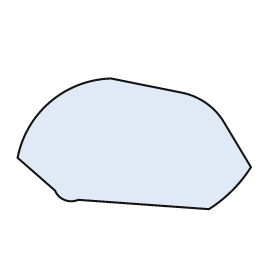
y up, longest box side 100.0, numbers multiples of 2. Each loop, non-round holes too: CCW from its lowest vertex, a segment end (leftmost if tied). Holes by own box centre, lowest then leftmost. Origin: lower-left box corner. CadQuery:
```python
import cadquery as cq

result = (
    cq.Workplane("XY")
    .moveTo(82.0, 0.0)
    .threePointArc((92.0, 8.0), (100.0, 18.0))
    .lineTo(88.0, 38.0)
    .threePointArc((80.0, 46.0), (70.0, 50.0))
    .lineTo(40.0, 56.0)
    .threePointArc((14.0, 46.0), (0.0, 22.0))
    .lineTo(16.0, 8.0)
    .threePointArc((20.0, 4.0), (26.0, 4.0))
    .close()
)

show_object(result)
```